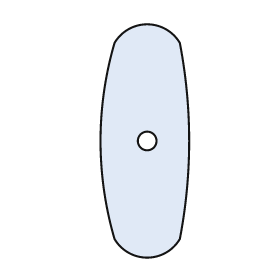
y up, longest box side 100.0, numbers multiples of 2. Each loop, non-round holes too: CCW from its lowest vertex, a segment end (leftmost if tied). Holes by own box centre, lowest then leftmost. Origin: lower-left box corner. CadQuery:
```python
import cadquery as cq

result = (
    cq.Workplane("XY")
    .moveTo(6.0, 8.0)
    .threePointArc((20.0, 0.0), (34.0, 8.0))
    .threePointArc((38.0, 50.0), (34.0, 92.0))
    .threePointArc((20.0, 100.0), (6.0, 92.0))
    .threePointArc((0.0, 50.0), (6.0, 8.0))
    .close()
    .moveTo(20.0, 50.0)
    .circle(4.0)
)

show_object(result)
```